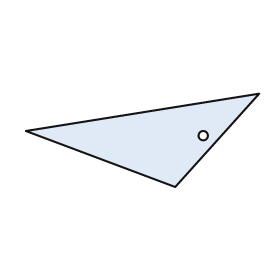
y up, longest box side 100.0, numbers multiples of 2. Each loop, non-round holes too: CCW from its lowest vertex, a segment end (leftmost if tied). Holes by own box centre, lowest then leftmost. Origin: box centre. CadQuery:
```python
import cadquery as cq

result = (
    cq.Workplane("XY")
    .moveTo(14.0, -20.0)
    .lineTo(50.0, 20.0)
    .lineTo(-50.0, 4.0)
    .close()
    .moveTo(26.0, 2.0)
    .circle(2.0)
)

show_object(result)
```